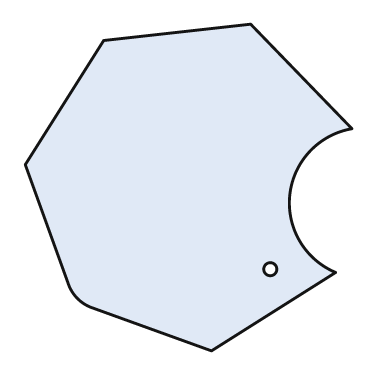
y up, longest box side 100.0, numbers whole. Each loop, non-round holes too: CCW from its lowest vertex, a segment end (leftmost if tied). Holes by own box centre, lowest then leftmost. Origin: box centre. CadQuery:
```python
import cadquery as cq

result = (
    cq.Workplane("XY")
    .moveTo(7.0, -50.0)
    .lineTo(45.0, -26.0)
    .threePointArc((31.0, -2.0), (50.0, 18.0))
    .lineTo(19.0, 50.0)
    .lineTo(-26.0, 45.0)
    .lineTo(-50.0, 7.0)
    .lineTo(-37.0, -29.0)
    .threePointArc((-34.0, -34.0), (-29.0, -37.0))
    .close()
    .moveTo(25.0, -25.0)
    .circle(2.0)
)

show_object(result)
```